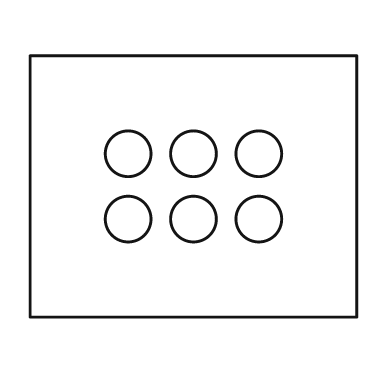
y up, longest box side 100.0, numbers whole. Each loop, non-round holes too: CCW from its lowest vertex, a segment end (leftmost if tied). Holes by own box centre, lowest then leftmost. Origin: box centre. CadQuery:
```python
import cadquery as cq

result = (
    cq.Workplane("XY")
    .moveTo(-50.0, -40.0)
    .lineTo(50.0, -40.0)
    .lineTo(50.0, 40.0)
    .lineTo(-50.0, 40.0)
    .close()
    .moveTo(-20.0, -10.0)
    .circle(7.0)
    .moveTo(0.0, -10.0)
    .circle(7.0)
    .moveTo(20.0, -10.0)
    .circle(7.0)
    .moveTo(-20.0, 10.0)
    .circle(7.0)
    .moveTo(0.0, 10.0)
    .circle(7.0)
    .moveTo(20.0, 10.0)
    .circle(7.0)
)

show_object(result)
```